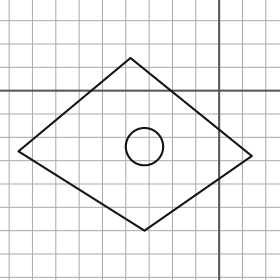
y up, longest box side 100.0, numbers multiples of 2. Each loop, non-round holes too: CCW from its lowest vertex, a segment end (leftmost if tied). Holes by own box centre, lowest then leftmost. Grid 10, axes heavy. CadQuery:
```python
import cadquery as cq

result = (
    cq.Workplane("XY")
    .moveTo(-32.0, -60.0)
    .lineTo(14.0, -28.0)
    .lineTo(-38.0, 14.0)
    .lineTo(-86.0, -26.0)
    .close()
    .moveTo(-32.0, -24.0)
    .circle(8.0)
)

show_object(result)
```